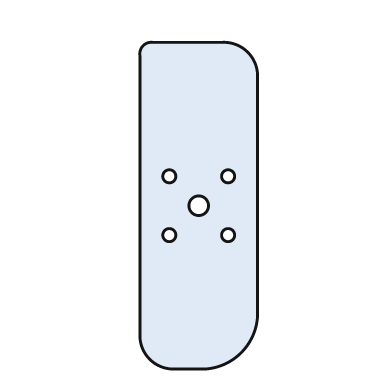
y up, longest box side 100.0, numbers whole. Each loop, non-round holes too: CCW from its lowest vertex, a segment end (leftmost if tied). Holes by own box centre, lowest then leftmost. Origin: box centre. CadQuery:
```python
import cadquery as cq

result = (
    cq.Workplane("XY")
    .moveTo(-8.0, -50.0)
    .lineTo(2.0, -50.0)
    .threePointArc((13.0, -45.0), (18.0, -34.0))
    .lineTo(18.0, 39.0)
    .threePointArc((15.0, 47.0), (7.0, 50.0))
    .lineTo(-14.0, 50.0)
    .threePointArc((-17.0, 49.0), (-18.0, 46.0))
    .lineTo(-18.0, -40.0)
    .threePointArc((-15.0, -47.0), (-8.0, -50.0))
    .close()
    .moveTo(-9.0, -9.0)
    .circle(2.0)
    .moveTo(9.0, -9.0)
    .circle(2.0)
    .moveTo(0.0, 0.0)
    .circle(3.0)
    .moveTo(-9.0, 9.0)
    .circle(2.0)
    .moveTo(9.0, 9.0)
    .circle(2.0)
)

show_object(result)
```